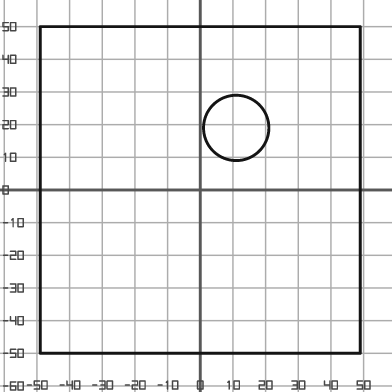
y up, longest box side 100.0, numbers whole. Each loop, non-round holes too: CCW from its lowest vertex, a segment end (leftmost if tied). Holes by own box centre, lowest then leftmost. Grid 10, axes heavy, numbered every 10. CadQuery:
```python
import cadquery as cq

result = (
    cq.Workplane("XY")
    .moveTo(-49.0, -50.0)
    .lineTo(49.0, -50.0)
    .lineTo(49.0, 50.0)
    .lineTo(-49.0, 50.0)
    .close()
    .moveTo(11.0, 19.0)
    .circle(10.0)
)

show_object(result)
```